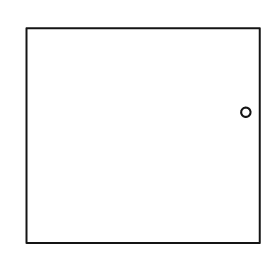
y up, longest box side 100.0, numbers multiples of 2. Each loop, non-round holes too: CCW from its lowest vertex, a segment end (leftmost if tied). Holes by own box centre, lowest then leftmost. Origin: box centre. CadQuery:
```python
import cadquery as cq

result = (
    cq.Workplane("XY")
    .moveTo(-50.0, -46.0)
    .lineTo(50.0, -46.0)
    .lineTo(50.0, 46.0)
    .lineTo(-50.0, 46.0)
    .close()
    .moveTo(44.0, 10.0)
    .circle(2.0)
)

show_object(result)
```